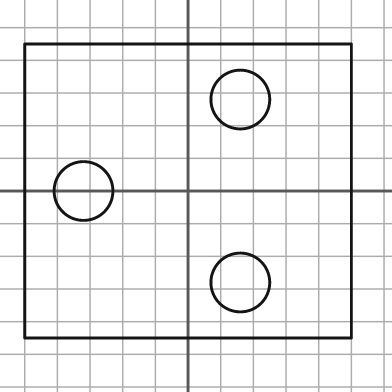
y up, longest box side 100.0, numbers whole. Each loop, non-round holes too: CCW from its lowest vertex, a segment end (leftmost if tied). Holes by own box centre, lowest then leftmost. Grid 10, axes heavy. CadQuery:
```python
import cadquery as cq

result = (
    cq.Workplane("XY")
    .moveTo(-50.0, -45.0)
    .lineTo(50.0, -45.0)
    .lineTo(50.0, 45.0)
    .lineTo(-50.0, 45.0)
    .close()
    .moveTo(16.0, -28.0)
    .circle(9.0)
    .moveTo(-32.0, 0.0)
    .circle(9.0)
    .moveTo(16.0, 28.0)
    .circle(9.0)
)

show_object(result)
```